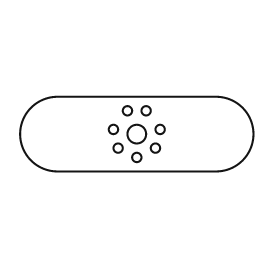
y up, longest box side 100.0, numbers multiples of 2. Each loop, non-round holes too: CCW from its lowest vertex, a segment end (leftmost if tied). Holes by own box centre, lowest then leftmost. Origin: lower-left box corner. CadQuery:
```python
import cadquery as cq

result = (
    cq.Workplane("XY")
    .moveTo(16.0, 0.0)
    .lineTo(84.0, 0.0)
    .threePointArc((100.0, 16.0), (84.0, 32.0))
    .lineTo(16.0, 32.0)
    .threePointArc((0.0, 16.0), (16.0, 0.0))
    .close()
    .moveTo(50.0, 6.0)
    .circle(2.0)
    .moveTo(42.0, 10.0)
    .circle(2.0)
    .moveTo(58.0, 10.0)
    .circle(2.0)
    .moveTo(50.0, 16.0)
    .circle(4.0)
    .moveTo(40.0, 18.0)
    .circle(2.0)
    .moveTo(60.0, 18.0)
    .circle(2.0)
    .moveTo(46.0, 26.0)
    .circle(2.0)
    .moveTo(54.0, 26.0)
    .circle(2.0)
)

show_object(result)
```